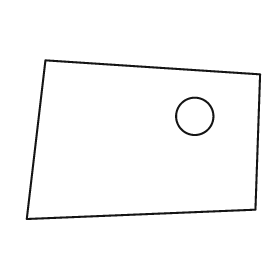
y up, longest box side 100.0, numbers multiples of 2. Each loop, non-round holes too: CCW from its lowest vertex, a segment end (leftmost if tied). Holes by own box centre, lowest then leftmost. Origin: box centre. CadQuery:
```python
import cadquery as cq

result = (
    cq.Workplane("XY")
    .moveTo(-50.0, -34.0)
    .lineTo(48.0, -30.0)
    .lineTo(50.0, 28.0)
    .lineTo(-42.0, 34.0)
    .close()
    .moveTo(22.0, 10.0)
    .circle(8.0)
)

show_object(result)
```